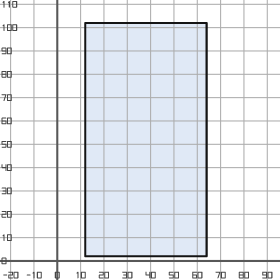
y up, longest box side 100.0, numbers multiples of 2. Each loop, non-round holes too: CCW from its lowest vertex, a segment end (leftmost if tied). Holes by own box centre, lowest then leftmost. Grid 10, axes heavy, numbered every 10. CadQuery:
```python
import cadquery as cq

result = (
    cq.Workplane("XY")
    .moveTo(12.0, 2.0)
    .lineTo(64.0, 2.0)
    .lineTo(64.0, 102.0)
    .lineTo(12.0, 102.0)
    .close()
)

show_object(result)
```